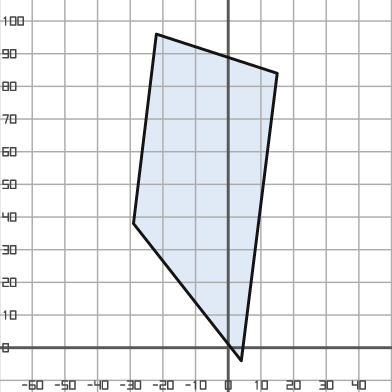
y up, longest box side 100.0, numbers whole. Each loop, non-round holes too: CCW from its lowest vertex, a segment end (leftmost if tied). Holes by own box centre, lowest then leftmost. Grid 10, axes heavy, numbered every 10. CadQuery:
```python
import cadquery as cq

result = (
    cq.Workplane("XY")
    .moveTo(4.0, -4.0)
    .lineTo(15.0, 84.0)
    .lineTo(-22.0, 96.0)
    .lineTo(-29.0, 38.0)
    .close()
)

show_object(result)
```